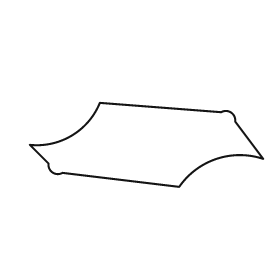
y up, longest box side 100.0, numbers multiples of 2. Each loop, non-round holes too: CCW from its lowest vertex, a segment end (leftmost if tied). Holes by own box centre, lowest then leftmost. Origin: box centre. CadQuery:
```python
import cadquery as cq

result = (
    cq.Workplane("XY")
    .moveTo(14.0, -18.0)
    .threePointArc((30.0, -6.0), (50.0, -6.0))
    .lineTo(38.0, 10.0)
    .threePointArc((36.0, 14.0), (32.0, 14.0))
    .lineTo(-20.0, 18.0)
    .threePointArc((-32.0, 4.0), (-50.0, 0.0))
    .lineTo(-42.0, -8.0)
    .threePointArc((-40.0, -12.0), (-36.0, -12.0))
    .close()
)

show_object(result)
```